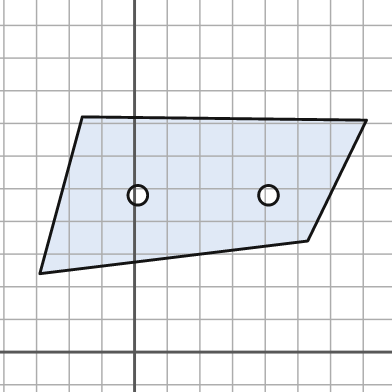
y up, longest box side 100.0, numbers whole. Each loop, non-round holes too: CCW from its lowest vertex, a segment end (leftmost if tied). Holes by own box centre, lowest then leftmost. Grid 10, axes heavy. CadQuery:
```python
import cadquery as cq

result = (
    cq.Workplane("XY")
    .moveTo(-29.0, 24.0)
    .lineTo(53.0, 34.0)
    .lineTo(71.0, 71.0)
    .lineTo(-16.0, 72.0)
    .close()
    .moveTo(1.0, 48.0)
    .circle(3.0)
    .moveTo(41.0, 48.0)
    .circle(3.0)
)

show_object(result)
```